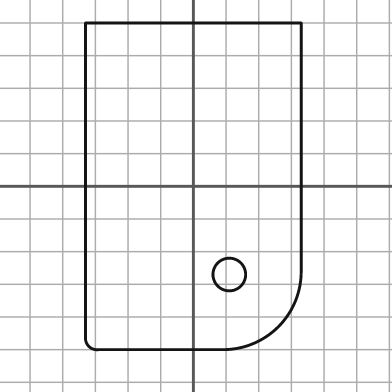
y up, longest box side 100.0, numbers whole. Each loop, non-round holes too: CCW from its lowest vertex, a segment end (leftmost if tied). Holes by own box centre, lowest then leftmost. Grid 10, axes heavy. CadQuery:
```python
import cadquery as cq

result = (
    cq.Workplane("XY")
    .moveTo(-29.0, -50.0)
    .lineTo(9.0, -50.0)
    .threePointArc((26.0, -43.0), (33.0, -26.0))
    .lineTo(33.0, 50.0)
    .lineTo(-33.0, 50.0)
    .lineTo(-33.0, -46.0)
    .threePointArc((-32.0, -49.0), (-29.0, -50.0))
    .close()
    .moveTo(11.0, -27.0)
    .circle(5.0)
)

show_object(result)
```